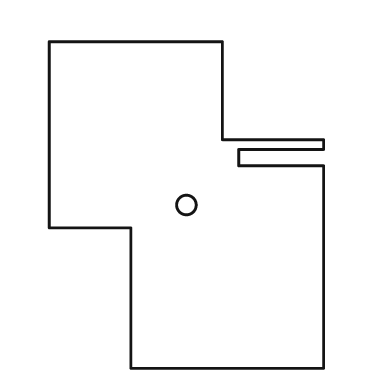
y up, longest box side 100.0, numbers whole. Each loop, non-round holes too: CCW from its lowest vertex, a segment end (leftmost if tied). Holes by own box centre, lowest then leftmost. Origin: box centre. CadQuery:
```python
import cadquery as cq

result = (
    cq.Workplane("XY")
    .moveTo(-17.0, -50.0)
    .lineTo(42.0, -50.0)
    .lineTo(42.0, 12.0)
    .lineTo(16.0, 12.0)
    .lineTo(16.0, 17.0)
    .lineTo(42.0, 17.0)
    .lineTo(42.0, 20.0)
    .lineTo(11.0, 20.0)
    .lineTo(11.0, 50.0)
    .lineTo(-42.0, 50.0)
    .lineTo(-42.0, -7.0)
    .lineTo(-17.0, -7.0)
    .close()
    .moveTo(0.0, 0.0)
    .circle(3.0)
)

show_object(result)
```